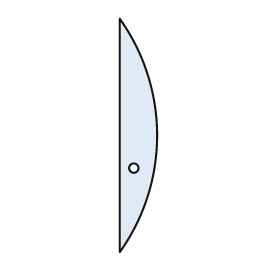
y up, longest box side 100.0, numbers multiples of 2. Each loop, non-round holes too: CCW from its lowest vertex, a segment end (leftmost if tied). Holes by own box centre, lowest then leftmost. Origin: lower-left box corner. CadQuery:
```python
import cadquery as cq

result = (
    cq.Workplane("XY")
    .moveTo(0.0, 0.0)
    .threePointArc((16.0, 50.0), (0.0, 100.0))
    .close()
    .moveTo(6.0, 36.0)
    .circle(2.0)
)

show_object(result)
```